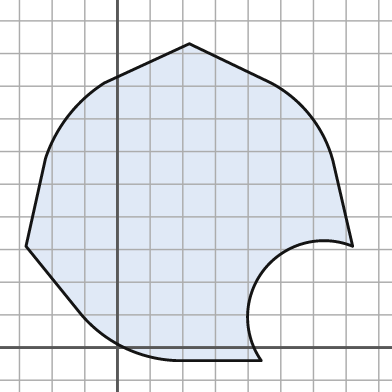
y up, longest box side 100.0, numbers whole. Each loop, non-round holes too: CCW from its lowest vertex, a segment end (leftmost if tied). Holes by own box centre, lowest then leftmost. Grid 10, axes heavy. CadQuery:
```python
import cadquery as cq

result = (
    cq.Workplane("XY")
    .moveTo(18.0, -4.0)
    .lineTo(44.0, -4.0)
    .threePointArc((45.0, 24.0), (72.0, 31.0))
    .lineTo(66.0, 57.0)
    .threePointArc((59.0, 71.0), (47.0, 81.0))
    .lineTo(22.0, 93.0)
    .lineTo(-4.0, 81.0)
    .threePointArc((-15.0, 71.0), (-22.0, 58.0))
    .lineTo(-28.0, 31.0)
    .lineTo(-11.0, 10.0)
    .threePointArc((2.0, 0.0), (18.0, -4.0))
    .close()
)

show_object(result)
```